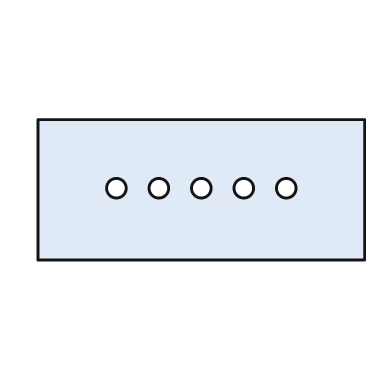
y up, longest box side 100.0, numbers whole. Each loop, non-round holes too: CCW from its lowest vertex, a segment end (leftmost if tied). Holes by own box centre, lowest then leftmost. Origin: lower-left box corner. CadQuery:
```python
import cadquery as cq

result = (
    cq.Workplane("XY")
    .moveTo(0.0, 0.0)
    .lineTo(100.0, 0.0)
    .lineTo(100.0, 43.0)
    .lineTo(0.0, 43.0)
    .close()
    .moveTo(24.0, 22.0)
    .circle(3.0)
    .moveTo(37.0, 22.0)
    .circle(3.0)
    .moveTo(50.0, 22.0)
    .circle(3.0)
    .moveTo(63.0, 22.0)
    .circle(3.0)
    .moveTo(76.0, 22.0)
    .circle(3.0)
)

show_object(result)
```